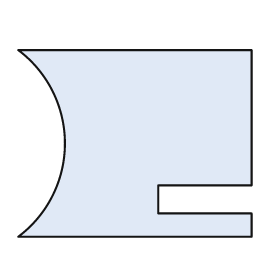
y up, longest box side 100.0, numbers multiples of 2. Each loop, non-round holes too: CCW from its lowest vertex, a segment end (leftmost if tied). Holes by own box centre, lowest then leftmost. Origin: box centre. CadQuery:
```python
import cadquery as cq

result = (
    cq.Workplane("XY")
    .moveTo(-50.0, -40.0)
    .lineTo(50.0, -40.0)
    .lineTo(50.0, -30.0)
    .lineTo(10.0, -30.0)
    .lineTo(10.0, -18.0)
    .lineTo(50.0, -18.0)
    .lineTo(50.0, 40.0)
    .lineTo(-50.0, 40.0)
    .threePointArc((-30.0, 0.0), (-50.0, -40.0))
    .close()
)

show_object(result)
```